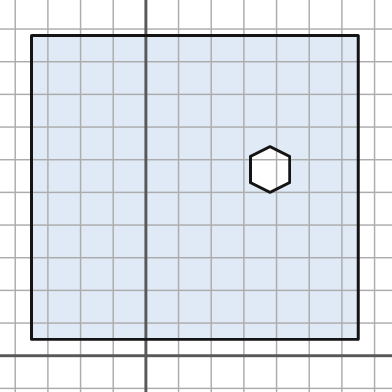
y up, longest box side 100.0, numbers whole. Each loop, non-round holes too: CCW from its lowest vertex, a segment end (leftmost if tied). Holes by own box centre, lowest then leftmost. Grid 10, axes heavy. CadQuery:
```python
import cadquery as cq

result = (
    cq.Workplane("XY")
    .moveTo(-35.0, 5.0)
    .lineTo(65.0, 5.0)
    .lineTo(65.0, 98.0)
    .lineTo(-35.0, 98.0)
    .close()
    .moveTo(38.0, 50.0)
    .lineTo(44.0, 53.0)
    .lineTo(44.0, 61.0)
    .lineTo(38.0, 64.0)
    .lineTo(32.0, 61.0)
    .lineTo(32.0, 53.0)
    .close()
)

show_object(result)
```